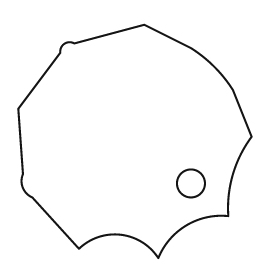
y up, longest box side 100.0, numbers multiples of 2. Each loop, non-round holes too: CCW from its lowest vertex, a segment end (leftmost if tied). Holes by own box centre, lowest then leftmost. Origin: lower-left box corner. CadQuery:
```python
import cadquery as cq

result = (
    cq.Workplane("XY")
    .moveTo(60.0, 0.0)
    .threePointArc((72.0, 14.0), (90.0, 18.0))
    .threePointArc((92.0, 36.0), (100.0, 52.0))
    .lineTo(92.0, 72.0)
    .threePointArc((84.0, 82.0), (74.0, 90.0))
    .lineTo(54.0, 100.0)
    .lineTo(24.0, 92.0)
    .threePointArc((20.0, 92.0), (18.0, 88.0))
    .lineTo(0.0, 64.0)
    .lineTo(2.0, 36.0)
    .threePointArc((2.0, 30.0), (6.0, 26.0))
    .lineTo(26.0, 4.0)
    .threePointArc((44.0, 10.0), (60.0, 0.0))
    .close()
    .moveTo(74.0, 32.0)
    .circle(6.0)
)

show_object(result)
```